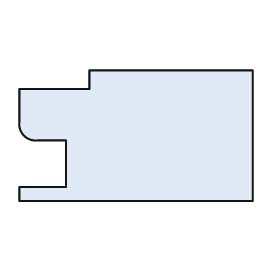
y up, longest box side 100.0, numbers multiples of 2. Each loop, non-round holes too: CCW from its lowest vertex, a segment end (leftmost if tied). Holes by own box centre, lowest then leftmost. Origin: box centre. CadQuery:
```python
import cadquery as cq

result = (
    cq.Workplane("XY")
    .moveTo(-50.0, -28.0)
    .lineTo(50.0, -28.0)
    .lineTo(50.0, 28.0)
    .lineTo(-20.0, 28.0)
    .lineTo(-20.0, 20.0)
    .lineTo(-50.0, 20.0)
    .lineTo(-50.0, 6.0)
    .threePointArc((-48.0, 0.0), (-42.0, -2.0))
    .lineTo(-30.0, -2.0)
    .lineTo(-30.0, -22.0)
    .lineTo(-50.0, -22.0)
    .close()
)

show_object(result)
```